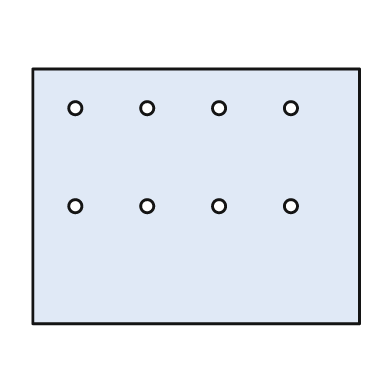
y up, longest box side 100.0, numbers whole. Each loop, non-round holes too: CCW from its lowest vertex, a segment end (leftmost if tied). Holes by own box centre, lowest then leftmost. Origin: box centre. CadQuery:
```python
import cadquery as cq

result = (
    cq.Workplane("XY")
    .moveTo(-50.0, -39.0)
    .lineTo(50.0, -39.0)
    .lineTo(50.0, 39.0)
    .lineTo(-50.0, 39.0)
    .close()
    .moveTo(-37.0, -3.0)
    .circle(2.0)
    .moveTo(-15.0, -3.0)
    .circle(2.0)
    .moveTo(7.0, -3.0)
    .circle(2.0)
    .moveTo(29.0, -3.0)
    .circle(2.0)
    .moveTo(-37.0, 27.0)
    .circle(2.0)
    .moveTo(-15.0, 27.0)
    .circle(2.0)
    .moveTo(7.0, 27.0)
    .circle(2.0)
    .moveTo(29.0, 27.0)
    .circle(2.0)
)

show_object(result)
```